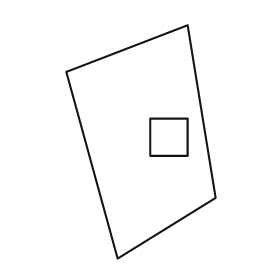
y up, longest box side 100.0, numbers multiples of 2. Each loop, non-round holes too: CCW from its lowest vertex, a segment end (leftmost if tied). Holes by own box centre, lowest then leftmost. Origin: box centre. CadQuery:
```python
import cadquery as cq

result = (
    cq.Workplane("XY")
    .moveTo(-10.0, -50.0)
    .lineTo(32.0, -24.0)
    .lineTo(20.0, 50.0)
    .lineTo(-32.0, 30.0)
    .close()
    .moveTo(4.0, -6.0)
    .lineTo(20.0, -6.0)
    .lineTo(20.0, 10.0)
    .lineTo(4.0, 10.0)
    .close()
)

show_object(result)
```